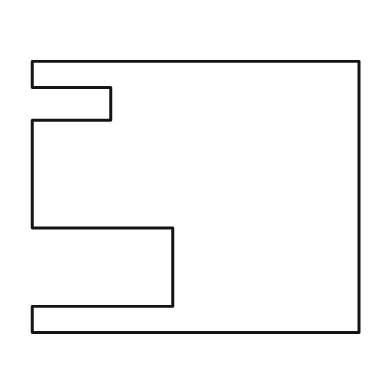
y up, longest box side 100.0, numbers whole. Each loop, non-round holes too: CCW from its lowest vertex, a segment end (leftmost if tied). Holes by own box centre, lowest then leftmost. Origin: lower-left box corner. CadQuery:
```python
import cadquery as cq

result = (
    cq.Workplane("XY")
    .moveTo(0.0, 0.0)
    .lineTo(100.0, 0.0)
    .lineTo(100.0, 83.0)
    .lineTo(0.0, 83.0)
    .lineTo(0.0, 75.0)
    .lineTo(24.0, 75.0)
    .lineTo(24.0, 65.0)
    .lineTo(0.0, 65.0)
    .lineTo(0.0, 32.0)
    .lineTo(43.0, 32.0)
    .lineTo(43.0, 8.0)
    .lineTo(0.0, 8.0)
    .close()
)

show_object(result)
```